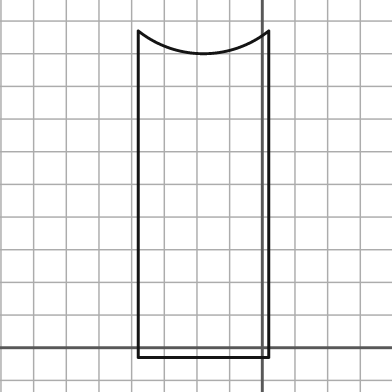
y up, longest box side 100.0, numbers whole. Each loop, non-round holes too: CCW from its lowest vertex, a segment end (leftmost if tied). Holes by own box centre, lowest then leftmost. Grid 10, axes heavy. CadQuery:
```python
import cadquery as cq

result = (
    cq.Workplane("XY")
    .moveTo(-38.0, -3.0)
    .lineTo(2.0, -3.0)
    .lineTo(2.0, 97.0)
    .threePointArc((-18.0, 90.0), (-38.0, 97.0))
    .close()
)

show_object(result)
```